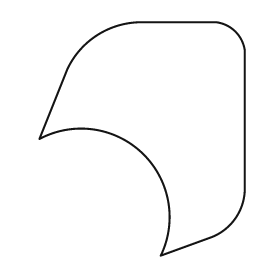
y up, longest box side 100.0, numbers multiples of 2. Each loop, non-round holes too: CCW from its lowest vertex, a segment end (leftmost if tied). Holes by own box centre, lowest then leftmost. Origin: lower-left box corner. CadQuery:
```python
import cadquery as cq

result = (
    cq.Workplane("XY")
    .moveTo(52.0, 0.0)
    .lineTo(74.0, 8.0)
    .threePointArc((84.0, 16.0), (88.0, 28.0))
    .lineTo(88.0, 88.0)
    .threePointArc((84.0, 96.0), (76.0, 100.0))
    .lineTo(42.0, 100.0)
    .threePointArc((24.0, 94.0), (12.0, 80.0))
    .lineTo(0.0, 50.0)
    .threePointArc((44.0, 44.0), (52.0, 0.0))
    .close()
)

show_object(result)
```